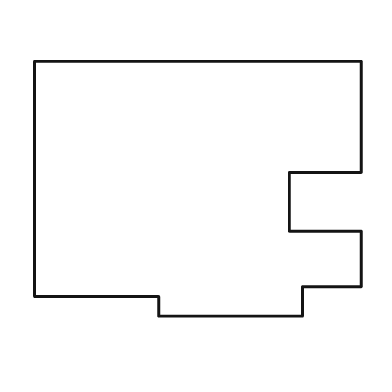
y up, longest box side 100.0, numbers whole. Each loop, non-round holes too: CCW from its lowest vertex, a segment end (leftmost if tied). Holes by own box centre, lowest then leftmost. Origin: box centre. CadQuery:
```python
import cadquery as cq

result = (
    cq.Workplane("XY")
    .moveTo(-12.0, -39.0)
    .lineTo(32.0, -39.0)
    .lineTo(32.0, -30.0)
    .lineTo(50.0, -30.0)
    .lineTo(50.0, -13.0)
    .lineTo(28.0, -13.0)
    .lineTo(28.0, 5.0)
    .lineTo(50.0, 5.0)
    .lineTo(50.0, 39.0)
    .lineTo(-50.0, 39.0)
    .lineTo(-50.0, -33.0)
    .lineTo(-12.0, -33.0)
    .close()
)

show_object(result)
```